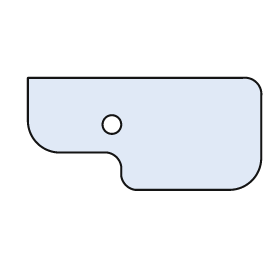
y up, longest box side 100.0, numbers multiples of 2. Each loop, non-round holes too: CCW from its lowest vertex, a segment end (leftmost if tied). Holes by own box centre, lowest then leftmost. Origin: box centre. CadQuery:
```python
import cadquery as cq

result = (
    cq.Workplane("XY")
    .moveTo(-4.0, -24.0)
    .lineTo(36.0, -24.0)
    .threePointArc((46.0, -20.0), (50.0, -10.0))
    .lineTo(50.0, 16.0)
    .threePointArc((48.0, 22.0), (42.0, 24.0))
    .lineTo(-50.0, 24.0)
    .lineTo(-50.0, 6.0)
    .threePointArc((-46.0, -4.0), (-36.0, -8.0))
    .lineTo(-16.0, -8.0)
    .threePointArc((-12.0, -10.0), (-10.0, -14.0))
    .lineTo(-10.0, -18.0)
    .threePointArc((-8.0, -22.0), (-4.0, -24.0))
    .close()
    .moveTo(-14.0, 4.0)
    .circle(4.0)
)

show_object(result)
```